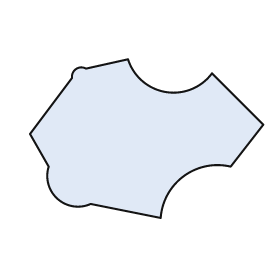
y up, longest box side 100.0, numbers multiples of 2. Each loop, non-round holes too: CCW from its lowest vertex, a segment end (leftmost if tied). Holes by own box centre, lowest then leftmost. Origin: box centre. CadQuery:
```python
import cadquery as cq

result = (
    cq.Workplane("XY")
    .moveTo(6.0, -34.0)
    .threePointArc((16.0, -16.0), (36.0, -12.0))
    .lineTo(50.0, 6.0)
    .lineTo(28.0, 28.0)
    .threePointArc((8.0, 20.0), (-8.0, 34.0))
    .lineTo(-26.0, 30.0)
    .threePointArc((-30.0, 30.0), (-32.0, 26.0))
    .lineTo(-50.0, 2.0)
    .lineTo(-42.0, -12.0)
    .threePointArc((-38.0, -26.0), (-24.0, -28.0))
    .close()
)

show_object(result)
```